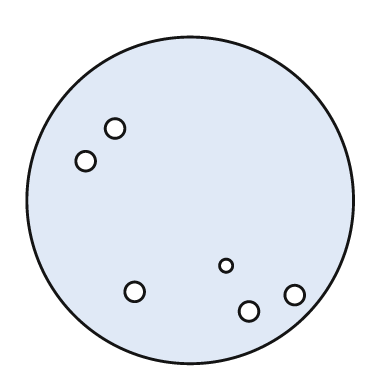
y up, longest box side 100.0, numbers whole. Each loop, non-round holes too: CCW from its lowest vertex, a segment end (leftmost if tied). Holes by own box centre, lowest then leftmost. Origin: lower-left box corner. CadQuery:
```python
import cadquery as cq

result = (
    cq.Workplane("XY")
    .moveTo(50.0, 50.0)
    .circle(50.0)
    .moveTo(68.0, 16.0)
    .circle(3.0)
    .moveTo(82.0, 21.0)
    .circle(3.0)
    .moveTo(33.0, 22.0)
    .circle(3.0)
    .moveTo(61.0, 30.0)
    .circle(2.0)
    .moveTo(18.0, 62.0)
    .circle(3.0)
    .moveTo(27.0, 72.0)
    .circle(3.0)
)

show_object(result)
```